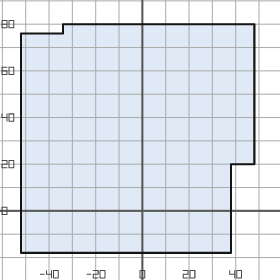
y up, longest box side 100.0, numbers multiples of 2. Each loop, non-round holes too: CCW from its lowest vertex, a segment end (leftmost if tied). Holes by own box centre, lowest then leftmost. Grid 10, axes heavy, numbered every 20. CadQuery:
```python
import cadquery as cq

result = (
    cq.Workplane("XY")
    .moveTo(-52.0, -18.0)
    .lineTo(38.0, -18.0)
    .lineTo(38.0, 20.0)
    .lineTo(48.0, 20.0)
    .lineTo(48.0, 80.0)
    .lineTo(-34.0, 80.0)
    .lineTo(-34.0, 76.0)
    .lineTo(-52.0, 76.0)
    .close()
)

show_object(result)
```